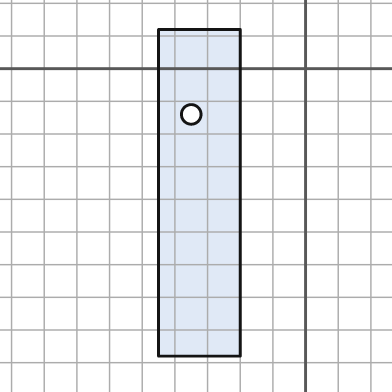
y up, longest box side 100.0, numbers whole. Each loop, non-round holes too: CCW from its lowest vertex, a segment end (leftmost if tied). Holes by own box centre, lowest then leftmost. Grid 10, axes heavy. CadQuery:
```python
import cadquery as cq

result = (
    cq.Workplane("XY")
    .moveTo(-45.0, -88.0)
    .lineTo(-20.0, -88.0)
    .lineTo(-20.0, 12.0)
    .lineTo(-45.0, 12.0)
    .close()
    .moveTo(-35.0, -14.0)
    .circle(3.0)
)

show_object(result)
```